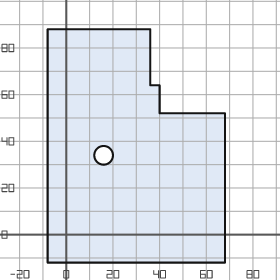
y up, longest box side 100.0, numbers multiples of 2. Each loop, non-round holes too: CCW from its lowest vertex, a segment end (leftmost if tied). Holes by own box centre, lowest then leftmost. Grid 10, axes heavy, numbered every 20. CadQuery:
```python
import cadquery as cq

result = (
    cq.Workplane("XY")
    .moveTo(-8.0, -12.0)
    .lineTo(68.0, -12.0)
    .lineTo(68.0, 52.0)
    .lineTo(40.0, 52.0)
    .lineTo(40.0, 64.0)
    .lineTo(36.0, 64.0)
    .lineTo(36.0, 88.0)
    .lineTo(-8.0, 88.0)
    .close()
    .moveTo(16.0, 34.0)
    .circle(4.0)
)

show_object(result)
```